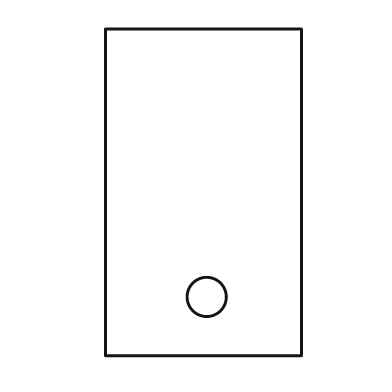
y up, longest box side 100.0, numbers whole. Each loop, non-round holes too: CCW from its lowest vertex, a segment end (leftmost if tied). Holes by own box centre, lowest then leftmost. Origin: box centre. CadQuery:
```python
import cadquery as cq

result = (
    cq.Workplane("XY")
    .moveTo(-30.0, -50.0)
    .lineTo(30.0, -50.0)
    .lineTo(30.0, 50.0)
    .lineTo(-30.0, 50.0)
    .close()
    .moveTo(1.0, -32.0)
    .circle(6.0)
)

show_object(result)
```